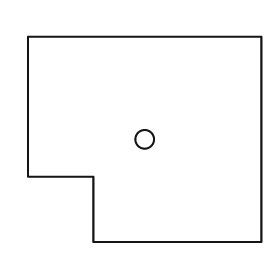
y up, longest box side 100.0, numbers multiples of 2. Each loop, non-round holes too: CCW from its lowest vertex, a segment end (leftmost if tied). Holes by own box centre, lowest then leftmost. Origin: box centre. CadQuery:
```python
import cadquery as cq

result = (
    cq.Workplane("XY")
    .moveTo(-22.0, -44.0)
    .lineTo(50.0, -44.0)
    .lineTo(50.0, 44.0)
    .lineTo(-50.0, 44.0)
    .lineTo(-50.0, -16.0)
    .lineTo(-22.0, -16.0)
    .close()
    .moveTo(0.0, 0.0)
    .circle(4.0)
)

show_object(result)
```